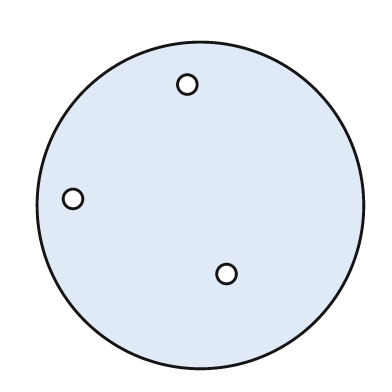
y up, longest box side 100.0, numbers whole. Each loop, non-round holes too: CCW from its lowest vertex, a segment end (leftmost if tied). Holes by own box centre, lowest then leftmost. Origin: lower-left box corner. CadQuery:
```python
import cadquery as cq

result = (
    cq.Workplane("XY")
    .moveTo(50.0, 50.0)
    .circle(50.0)
    .moveTo(58.0, 29.0)
    .circle(3.0)
    .moveTo(11.0, 52.0)
    .circle(3.0)
    .moveTo(46.0, 87.0)
    .circle(3.0)
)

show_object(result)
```